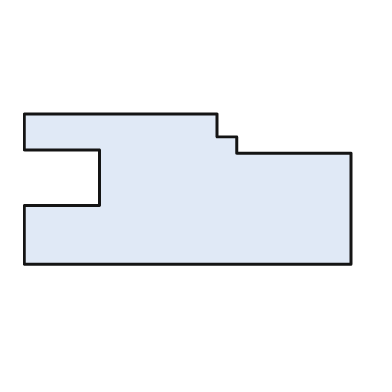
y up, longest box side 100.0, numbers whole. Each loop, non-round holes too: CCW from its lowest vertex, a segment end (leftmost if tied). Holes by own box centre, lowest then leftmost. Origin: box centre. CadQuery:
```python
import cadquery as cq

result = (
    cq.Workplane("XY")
    .moveTo(-50.0, -23.0)
    .lineTo(50.0, -23.0)
    .lineTo(50.0, 11.0)
    .lineTo(15.0, 11.0)
    .lineTo(15.0, 16.0)
    .lineTo(9.0, 16.0)
    .lineTo(9.0, 23.0)
    .lineTo(-50.0, 23.0)
    .lineTo(-50.0, 12.0)
    .lineTo(-27.0, 12.0)
    .lineTo(-27.0, -5.0)
    .lineTo(-50.0, -5.0)
    .close()
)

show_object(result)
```